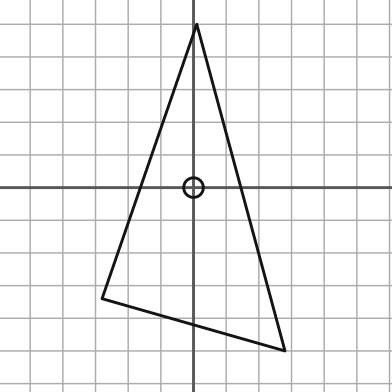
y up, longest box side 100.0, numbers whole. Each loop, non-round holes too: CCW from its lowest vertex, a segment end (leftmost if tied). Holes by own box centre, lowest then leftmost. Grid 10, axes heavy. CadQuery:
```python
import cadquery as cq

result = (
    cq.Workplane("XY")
    .moveTo(28.0, -50.0)
    .lineTo(1.0, 50.0)
    .lineTo(-28.0, -34.0)
    .close()
    .moveTo(0.0, 0.0)
    .circle(3.0)
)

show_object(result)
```